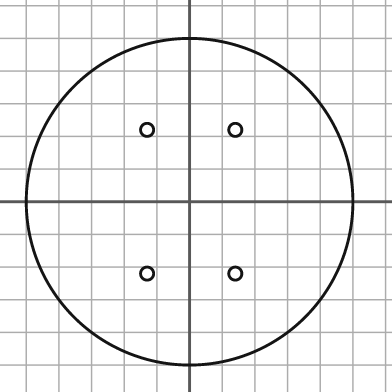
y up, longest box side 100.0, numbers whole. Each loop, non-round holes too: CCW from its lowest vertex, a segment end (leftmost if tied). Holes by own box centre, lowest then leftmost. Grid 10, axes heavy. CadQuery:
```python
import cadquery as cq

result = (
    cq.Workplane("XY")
    .moveTo(0.0, 0.0)
    .circle(50.0)
    .moveTo(-13.0, -22.0)
    .circle(2.0)
    .moveTo(14.0, -22.0)
    .circle(2.0)
    .moveTo(-13.0, 22.0)
    .circle(2.0)
    .moveTo(14.0, 22.0)
    .circle(2.0)
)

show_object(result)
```